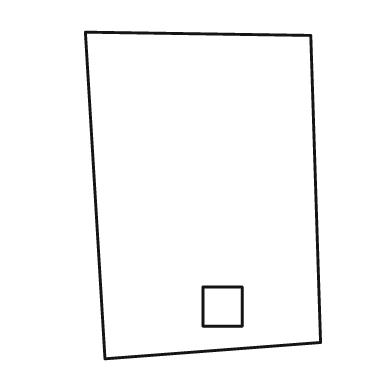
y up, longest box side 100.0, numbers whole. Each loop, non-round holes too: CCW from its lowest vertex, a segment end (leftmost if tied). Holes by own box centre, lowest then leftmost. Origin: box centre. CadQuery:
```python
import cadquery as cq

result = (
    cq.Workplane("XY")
    .moveTo(-30.0, -50.0)
    .lineTo(36.0, -45.0)
    .lineTo(33.0, 49.0)
    .lineTo(-36.0, 50.0)
    .close()
    .moveTo(0.0, -40.0)
    .lineTo(12.0, -40.0)
    .lineTo(12.0, -28.0)
    .lineTo(0.0, -28.0)
    .close()
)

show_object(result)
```